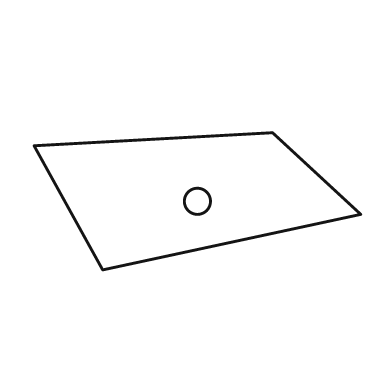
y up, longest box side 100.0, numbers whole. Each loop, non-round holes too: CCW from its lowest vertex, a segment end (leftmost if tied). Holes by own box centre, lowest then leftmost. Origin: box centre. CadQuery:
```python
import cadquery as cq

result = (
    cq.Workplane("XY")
    .moveTo(-29.0, -21.0)
    .lineTo(50.0, -4.0)
    .lineTo(23.0, 21.0)
    .lineTo(-50.0, 17.0)
    .close()
    .moveTo(0.0, 0.0)
    .circle(4.0)
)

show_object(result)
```